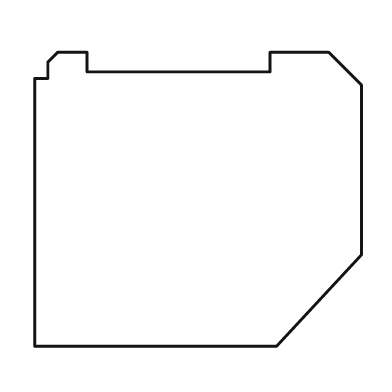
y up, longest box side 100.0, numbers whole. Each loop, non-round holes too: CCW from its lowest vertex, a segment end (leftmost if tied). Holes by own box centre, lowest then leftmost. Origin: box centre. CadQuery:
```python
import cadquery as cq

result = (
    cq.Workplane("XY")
    .moveTo(-50.0, -45.0)
    .lineTo(24.0, -45.0)
    .lineTo(50.0, -17.0)
    .lineTo(50.0, 35.0)
    .lineTo(40.0, 45.0)
    .lineTo(22.0, 45.0)
    .lineTo(22.0, 39.0)
    .lineTo(-34.0, 39.0)
    .lineTo(-34.0, 45.0)
    .lineTo(-43.0, 45.0)
    .lineTo(-46.0, 42.0)
    .lineTo(-46.0, 37.0)
    .lineTo(-50.0, 37.0)
    .close()
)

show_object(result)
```